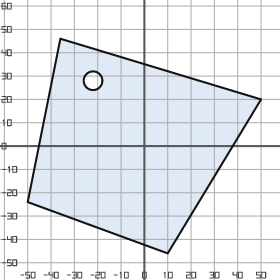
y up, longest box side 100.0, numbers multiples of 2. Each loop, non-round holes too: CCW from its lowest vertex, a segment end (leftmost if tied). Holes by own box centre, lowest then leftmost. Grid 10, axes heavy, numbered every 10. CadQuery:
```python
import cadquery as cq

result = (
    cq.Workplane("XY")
    .moveTo(10.0, -46.0)
    .lineTo(50.0, 20.0)
    .lineTo(-36.0, 46.0)
    .lineTo(-50.0, -24.0)
    .close()
    .moveTo(-22.0, 28.0)
    .circle(4.0)
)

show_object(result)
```